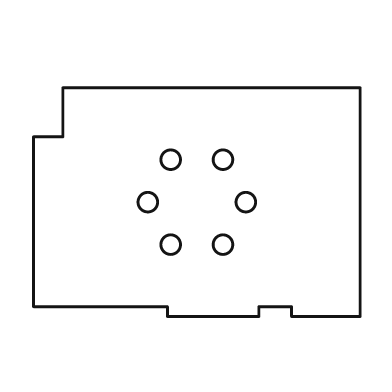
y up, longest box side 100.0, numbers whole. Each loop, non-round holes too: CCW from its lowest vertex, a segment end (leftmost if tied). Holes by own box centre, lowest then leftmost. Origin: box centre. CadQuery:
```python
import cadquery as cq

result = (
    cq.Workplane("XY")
    .moveTo(-9.0, -35.0)
    .lineTo(19.0, -35.0)
    .lineTo(19.0, -32.0)
    .lineTo(29.0, -32.0)
    .lineTo(29.0, -35.0)
    .lineTo(50.0, -35.0)
    .lineTo(50.0, 35.0)
    .lineTo(-41.0, 35.0)
    .lineTo(-41.0, 20.0)
    .lineTo(-50.0, 20.0)
    .lineTo(-50.0, -32.0)
    .lineTo(-9.0, -32.0)
    .close()
    .moveTo(-8.0, -13.0)
    .circle(3.0)
    .moveTo(8.0, -13.0)
    .circle(3.0)
    .moveTo(-15.0, 0.0)
    .circle(3.0)
    .moveTo(15.0, 0.0)
    .circle(3.0)
    .moveTo(-8.0, 13.0)
    .circle(3.0)
    .moveTo(8.0, 13.0)
    .circle(3.0)
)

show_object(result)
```